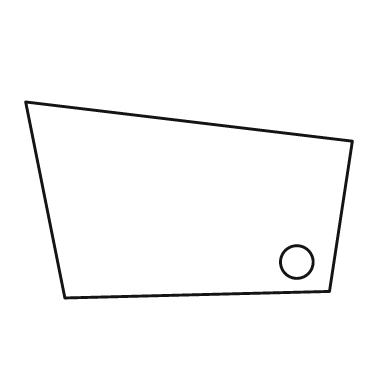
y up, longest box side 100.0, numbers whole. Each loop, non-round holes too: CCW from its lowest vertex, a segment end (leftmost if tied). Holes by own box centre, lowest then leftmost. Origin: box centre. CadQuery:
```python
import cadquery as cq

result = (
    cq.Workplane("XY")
    .moveTo(-38.0, -30.0)
    .lineTo(43.0, -28.0)
    .lineTo(50.0, 18.0)
    .lineTo(-50.0, 30.0)
    .close()
    .moveTo(33.0, -19.0)
    .circle(5.0)
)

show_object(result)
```